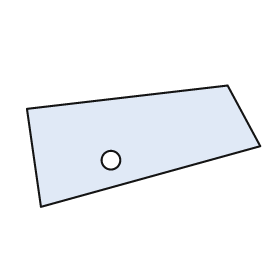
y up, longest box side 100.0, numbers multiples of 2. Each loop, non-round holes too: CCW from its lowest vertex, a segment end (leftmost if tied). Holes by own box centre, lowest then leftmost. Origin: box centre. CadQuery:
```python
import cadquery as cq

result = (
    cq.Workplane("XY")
    .moveTo(-44.0, -26.0)
    .lineTo(50.0, 0.0)
    .lineTo(36.0, 26.0)
    .lineTo(-50.0, 16.0)
    .close()
    .moveTo(-14.0, -6.0)
    .circle(4.0)
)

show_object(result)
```